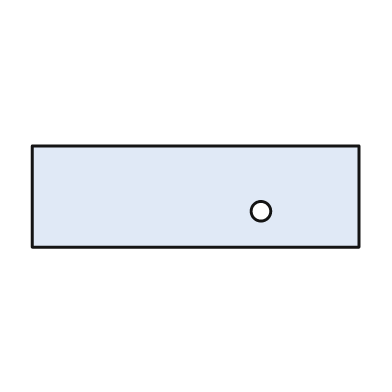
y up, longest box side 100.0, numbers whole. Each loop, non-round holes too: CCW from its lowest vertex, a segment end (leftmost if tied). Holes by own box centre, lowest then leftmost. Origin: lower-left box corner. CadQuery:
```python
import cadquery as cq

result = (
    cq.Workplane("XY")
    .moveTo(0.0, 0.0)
    .lineTo(100.0, 0.0)
    .lineTo(100.0, 31.0)
    .lineTo(0.0, 31.0)
    .close()
    .moveTo(70.0, 11.0)
    .circle(3.0)
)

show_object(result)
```